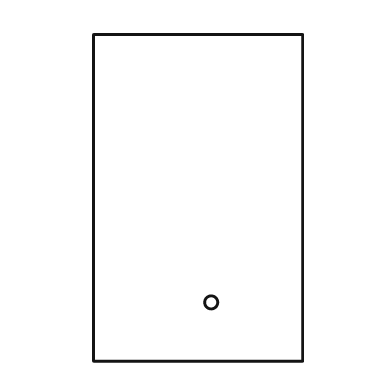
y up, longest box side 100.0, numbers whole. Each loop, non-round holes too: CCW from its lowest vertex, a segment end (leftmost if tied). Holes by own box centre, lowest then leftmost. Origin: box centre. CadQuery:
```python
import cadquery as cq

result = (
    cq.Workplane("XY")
    .moveTo(-32.0, -50.0)
    .lineTo(32.0, -50.0)
    .lineTo(32.0, 50.0)
    .lineTo(-32.0, 50.0)
    .close()
    .moveTo(4.0, -32.0)
    .circle(2.0)
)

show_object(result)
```